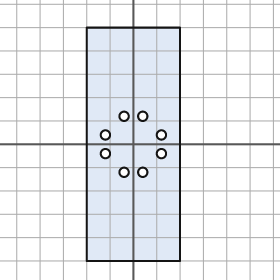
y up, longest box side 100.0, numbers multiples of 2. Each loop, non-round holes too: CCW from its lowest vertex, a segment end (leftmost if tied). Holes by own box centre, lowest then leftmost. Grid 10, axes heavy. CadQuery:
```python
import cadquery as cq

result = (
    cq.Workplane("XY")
    .moveTo(-20.0, -50.0)
    .lineTo(20.0, -50.0)
    .lineTo(20.0, 50.0)
    .lineTo(-20.0, 50.0)
    .close()
    .moveTo(-4.0, -12.0)
    .circle(2.0)
    .moveTo(4.0, -12.0)
    .circle(2.0)
    .moveTo(-12.0, -4.0)
    .circle(2.0)
    .moveTo(12.0, -4.0)
    .circle(2.0)
    .moveTo(-12.0, 4.0)
    .circle(2.0)
    .moveTo(12.0, 4.0)
    .circle(2.0)
    .moveTo(-4.0, 12.0)
    .circle(2.0)
    .moveTo(4.0, 12.0)
    .circle(2.0)
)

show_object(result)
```